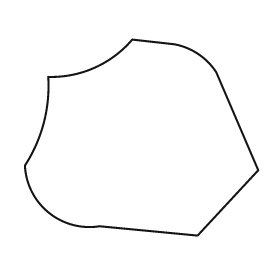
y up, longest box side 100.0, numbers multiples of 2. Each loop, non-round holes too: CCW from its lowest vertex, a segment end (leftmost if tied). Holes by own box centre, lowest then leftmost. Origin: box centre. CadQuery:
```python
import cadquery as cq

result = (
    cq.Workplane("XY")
    .moveTo(24.0, -42.0)
    .lineTo(50.0, -14.0)
    .lineTo(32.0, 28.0)
    .threePointArc((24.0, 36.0), (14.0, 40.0))
    .lineTo(-4.0, 42.0)
    .threePointArc((-20.0, 30.0), (-40.0, 26.0))
    .threePointArc((-42.0, 6.0), (-50.0, -12.0))
    .threePointArc((-40.0, -32.0), (-18.0, -38.0))
    .close()
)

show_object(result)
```